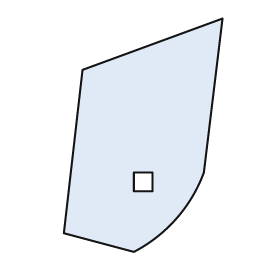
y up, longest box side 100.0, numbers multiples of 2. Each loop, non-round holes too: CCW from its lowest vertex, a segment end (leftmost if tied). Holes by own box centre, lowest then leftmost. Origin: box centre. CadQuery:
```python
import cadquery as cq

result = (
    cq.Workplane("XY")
    .moveTo(-4.0, -50.0)
    .threePointArc((14.0, -36.0), (26.0, -16.0))
    .lineTo(34.0, 50.0)
    .lineTo(-26.0, 28.0)
    .lineTo(-34.0, -42.0)
    .close()
    .moveTo(-4.0, -24.0)
    .lineTo(4.0, -24.0)
    .lineTo(4.0, -16.0)
    .lineTo(-4.0, -16.0)
    .close()
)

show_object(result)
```